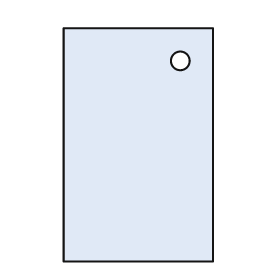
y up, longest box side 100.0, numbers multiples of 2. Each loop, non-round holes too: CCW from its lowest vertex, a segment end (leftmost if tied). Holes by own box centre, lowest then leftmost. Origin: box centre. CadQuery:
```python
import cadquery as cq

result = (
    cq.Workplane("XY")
    .moveTo(-32.0, -50.0)
    .lineTo(32.0, -50.0)
    .lineTo(32.0, 50.0)
    .lineTo(-32.0, 50.0)
    .close()
    .moveTo(18.0, 36.0)
    .circle(4.0)
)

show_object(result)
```